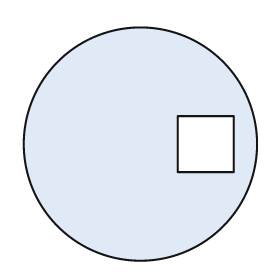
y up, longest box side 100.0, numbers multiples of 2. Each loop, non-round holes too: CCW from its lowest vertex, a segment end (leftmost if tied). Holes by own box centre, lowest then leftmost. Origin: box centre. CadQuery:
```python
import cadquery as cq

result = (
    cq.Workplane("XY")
    .moveTo(0.0, 0.0)
    .circle(50.0)
    .moveTo(16.0, -12.0)
    .lineTo(40.0, -12.0)
    .lineTo(40.0, 12.0)
    .lineTo(16.0, 12.0)
    .close()
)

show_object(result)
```